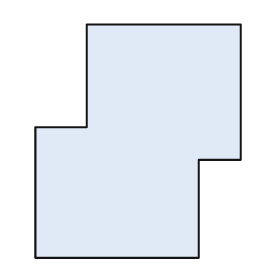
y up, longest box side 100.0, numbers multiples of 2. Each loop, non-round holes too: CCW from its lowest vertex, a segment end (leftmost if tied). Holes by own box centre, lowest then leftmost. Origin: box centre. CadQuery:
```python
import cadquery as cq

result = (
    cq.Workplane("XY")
    .moveTo(-44.0, -50.0)
    .lineTo(26.0, -50.0)
    .lineTo(26.0, -8.0)
    .lineTo(44.0, -8.0)
    .lineTo(44.0, 50.0)
    .lineTo(-22.0, 50.0)
    .lineTo(-22.0, 6.0)
    .lineTo(-44.0, 6.0)
    .close()
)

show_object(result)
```